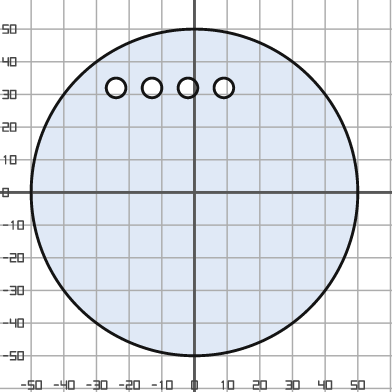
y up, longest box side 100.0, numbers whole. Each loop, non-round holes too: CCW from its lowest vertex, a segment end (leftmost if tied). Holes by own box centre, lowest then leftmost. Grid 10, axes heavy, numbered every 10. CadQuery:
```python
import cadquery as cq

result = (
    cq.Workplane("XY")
    .moveTo(0.0, 0.0)
    .circle(50.0)
    .moveTo(-24.0, 32.0)
    .circle(3.0)
    .moveTo(-13.0, 32.0)
    .circle(3.0)
    .moveTo(-2.0, 32.0)
    .circle(3.0)
    .moveTo(9.0, 32.0)
    .circle(3.0)
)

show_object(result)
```